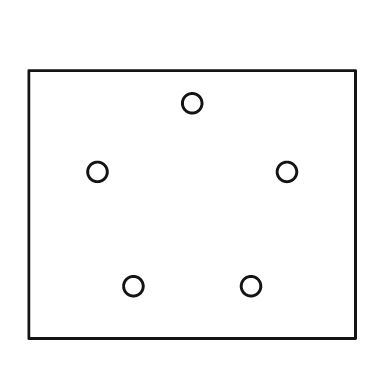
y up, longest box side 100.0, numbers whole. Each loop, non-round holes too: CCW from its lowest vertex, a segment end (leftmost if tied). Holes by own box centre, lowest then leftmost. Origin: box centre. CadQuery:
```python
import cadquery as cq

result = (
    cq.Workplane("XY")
    .moveTo(-50.0, -41.0)
    .lineTo(50.0, -41.0)
    .lineTo(50.0, 41.0)
    .lineTo(-50.0, 41.0)
    .close()
    .moveTo(-18.0, -25.0)
    .circle(3.0)
    .moveTo(18.0, -25.0)
    .circle(3.0)
    .moveTo(-29.0, 10.0)
    .circle(3.0)
    .moveTo(29.0, 10.0)
    .circle(3.0)
    .moveTo(0.0, 31.0)
    .circle(3.0)
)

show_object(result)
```